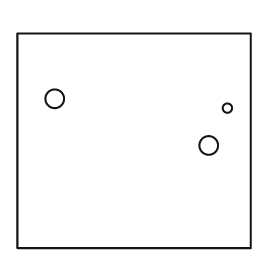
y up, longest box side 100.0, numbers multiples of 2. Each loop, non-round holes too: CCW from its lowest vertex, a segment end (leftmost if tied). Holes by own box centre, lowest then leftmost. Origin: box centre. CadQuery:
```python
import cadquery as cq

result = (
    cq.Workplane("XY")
    .moveTo(-50.0, -46.0)
    .lineTo(50.0, -46.0)
    .lineTo(50.0, 46.0)
    .lineTo(-50.0, 46.0)
    .close()
    .moveTo(32.0, -2.0)
    .circle(4.0)
    .moveTo(40.0, 14.0)
    .circle(2.0)
    .moveTo(-34.0, 18.0)
    .circle(4.0)
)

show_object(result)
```